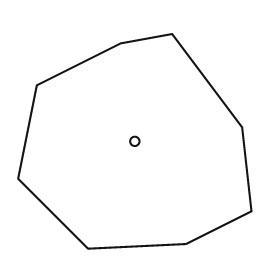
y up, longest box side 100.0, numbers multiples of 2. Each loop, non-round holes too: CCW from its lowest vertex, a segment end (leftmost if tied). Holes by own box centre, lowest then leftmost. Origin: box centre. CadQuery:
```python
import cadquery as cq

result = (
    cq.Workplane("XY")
    .moveTo(-20.0, -46.0)
    .lineTo(22.0, -44.0)
    .lineTo(50.0, -30.0)
    .lineTo(46.0, 6.0)
    .lineTo(16.0, 46.0)
    .lineTo(-6.0, 42.0)
    .lineTo(-42.0, 24.0)
    .lineTo(-50.0, -16.0)
    .close()
    .moveTo(0.0, 0.0)
    .circle(2.0)
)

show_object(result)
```